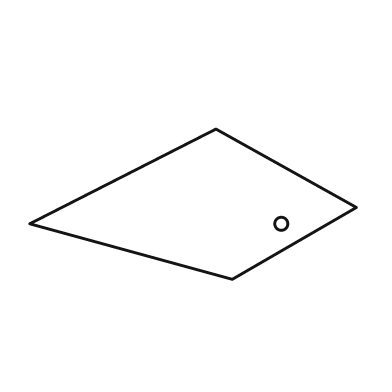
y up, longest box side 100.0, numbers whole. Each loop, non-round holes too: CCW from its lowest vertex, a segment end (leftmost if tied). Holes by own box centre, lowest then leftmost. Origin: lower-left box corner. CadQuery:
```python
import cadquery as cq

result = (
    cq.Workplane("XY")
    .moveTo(62.0, 0.0)
    .lineTo(100.0, 22.0)
    .lineTo(57.0, 46.0)
    .lineTo(0.0, 17.0)
    .close()
    .moveTo(77.0, 17.0)
    .circle(2.0)
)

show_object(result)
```